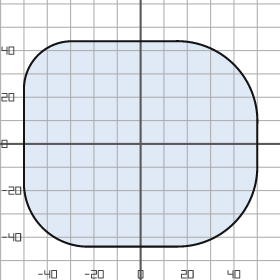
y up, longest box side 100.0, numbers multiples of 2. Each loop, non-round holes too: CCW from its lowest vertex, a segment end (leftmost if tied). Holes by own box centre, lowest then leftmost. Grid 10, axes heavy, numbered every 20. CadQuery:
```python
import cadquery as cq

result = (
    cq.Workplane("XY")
    .moveTo(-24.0, -44.0)
    .lineTo(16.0, -44.0)
    .threePointArc((40.0, -34.0), (50.0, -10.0))
    .lineTo(50.0, 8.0)
    .threePointArc((40.0, 34.0), (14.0, 44.0))
    .lineTo(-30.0, 44.0)
    .threePointArc((-44.0, 38.0), (-50.0, 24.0))
    .lineTo(-50.0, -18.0)
    .threePointArc((-42.0, -36.0), (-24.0, -44.0))
    .close()
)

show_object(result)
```